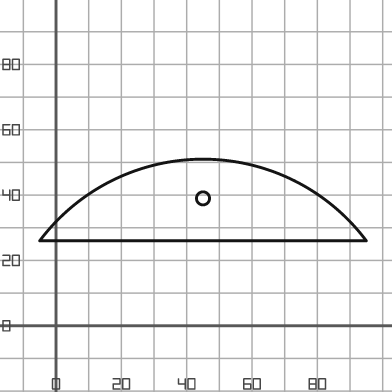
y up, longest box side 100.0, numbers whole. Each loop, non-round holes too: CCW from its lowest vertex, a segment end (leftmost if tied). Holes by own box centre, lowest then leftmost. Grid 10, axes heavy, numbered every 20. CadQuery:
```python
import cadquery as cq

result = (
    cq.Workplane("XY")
    .moveTo(-5.0, 26.0)
    .lineTo(95.0, 26.0)
    .threePointArc((45.0, 51.0), (-5.0, 26.0))
    .close()
    .moveTo(45.0, 39.0)
    .circle(2.0)
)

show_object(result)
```